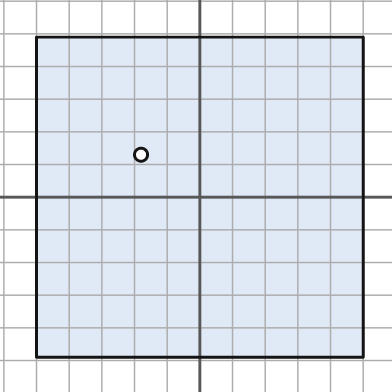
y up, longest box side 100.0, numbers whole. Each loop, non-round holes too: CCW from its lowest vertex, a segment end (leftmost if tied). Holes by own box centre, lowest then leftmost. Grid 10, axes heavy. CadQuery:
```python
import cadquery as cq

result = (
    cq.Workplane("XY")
    .moveTo(-50.0, -49.0)
    .lineTo(50.0, -49.0)
    .lineTo(50.0, 49.0)
    .lineTo(-50.0, 49.0)
    .close()
    .moveTo(-18.0, 13.0)
    .circle(2.0)
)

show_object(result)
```